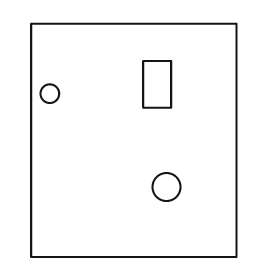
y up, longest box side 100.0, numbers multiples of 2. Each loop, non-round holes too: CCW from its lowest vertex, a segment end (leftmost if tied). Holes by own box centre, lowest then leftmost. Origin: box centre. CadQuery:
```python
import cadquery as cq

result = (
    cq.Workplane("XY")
    .moveTo(-44.0, -50.0)
    .lineTo(44.0, -50.0)
    .lineTo(44.0, 50.0)
    .lineTo(-44.0, 50.0)
    .close()
    .moveTo(14.0, -20.0)
    .circle(6.0)
    .moveTo(-36.0, 20.0)
    .circle(4.0)
    .moveTo(4.0, 14.0)
    .lineTo(16.0, 14.0)
    .lineTo(16.0, 34.0)
    .lineTo(4.0, 34.0)
    .close()
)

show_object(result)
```